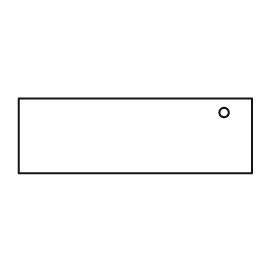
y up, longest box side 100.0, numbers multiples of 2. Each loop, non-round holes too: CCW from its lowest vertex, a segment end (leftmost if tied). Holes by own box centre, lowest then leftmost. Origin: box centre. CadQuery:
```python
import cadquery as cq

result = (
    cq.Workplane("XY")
    .moveTo(-50.0, -16.0)
    .lineTo(50.0, -16.0)
    .lineTo(50.0, 16.0)
    .lineTo(-50.0, 16.0)
    .close()
    .moveTo(38.0, 10.0)
    .circle(2.0)
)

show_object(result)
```